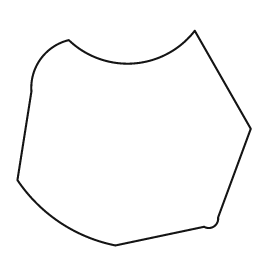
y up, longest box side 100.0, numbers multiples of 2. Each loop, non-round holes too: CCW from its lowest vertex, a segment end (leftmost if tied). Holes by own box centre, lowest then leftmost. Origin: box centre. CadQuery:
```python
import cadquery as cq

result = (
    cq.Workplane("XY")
    .moveTo(-8.0, -46.0)
    .lineTo(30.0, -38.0)
    .threePointArc((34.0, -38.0), (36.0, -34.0))
    .lineTo(50.0, 4.0)
    .lineTo(26.0, 46.0)
    .threePointArc((0.0, 32.0), (-28.0, 42.0))
    .threePointArc((-40.0, 34.0), (-44.0, 20.0))
    .lineTo(-50.0, -18.0)
    .threePointArc((-32.0, -36.0), (-8.0, -46.0))
    .close()
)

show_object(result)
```